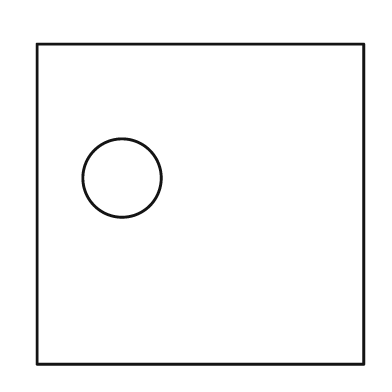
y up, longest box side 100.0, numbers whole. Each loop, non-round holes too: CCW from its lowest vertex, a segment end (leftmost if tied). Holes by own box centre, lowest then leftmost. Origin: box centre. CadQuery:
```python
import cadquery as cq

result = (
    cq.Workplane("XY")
    .moveTo(-50.0, -49.0)
    .lineTo(50.0, -49.0)
    .lineTo(50.0, 49.0)
    .lineTo(-50.0, 49.0)
    .close()
    .moveTo(-24.0, 8.0)
    .circle(12.0)
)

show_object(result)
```